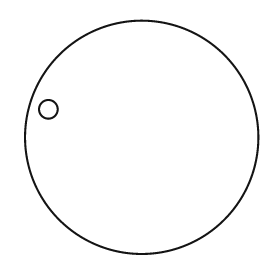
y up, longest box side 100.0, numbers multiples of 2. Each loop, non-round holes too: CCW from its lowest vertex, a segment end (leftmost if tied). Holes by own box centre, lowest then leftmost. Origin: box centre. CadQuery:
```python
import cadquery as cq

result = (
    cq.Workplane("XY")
    .moveTo(0.0, 0.0)
    .circle(50.0)
    .moveTo(-40.0, 12.0)
    .circle(4.0)
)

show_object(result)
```